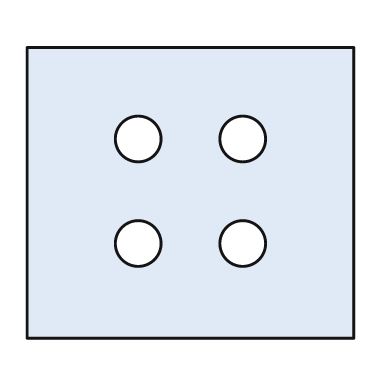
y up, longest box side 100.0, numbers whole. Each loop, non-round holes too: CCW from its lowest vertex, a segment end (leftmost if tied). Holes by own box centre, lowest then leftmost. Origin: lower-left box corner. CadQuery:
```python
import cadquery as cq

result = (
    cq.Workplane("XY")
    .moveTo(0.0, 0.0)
    .lineTo(100.0, 0.0)
    .lineTo(100.0, 89.0)
    .lineTo(0.0, 89.0)
    .close()
    .moveTo(34.0, 29.0)
    .circle(7.0)
    .moveTo(66.0, 29.0)
    .circle(7.0)
    .moveTo(34.0, 61.0)
    .circle(7.0)
    .moveTo(66.0, 61.0)
    .circle(7.0)
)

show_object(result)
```